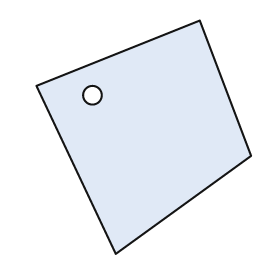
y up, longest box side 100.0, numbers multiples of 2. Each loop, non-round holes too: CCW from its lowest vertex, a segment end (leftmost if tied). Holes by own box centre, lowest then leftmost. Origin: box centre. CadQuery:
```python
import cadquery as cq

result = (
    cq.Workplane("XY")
    .moveTo(-12.0, -50.0)
    .lineTo(46.0, -8.0)
    .lineTo(24.0, 50.0)
    .lineTo(-46.0, 22.0)
    .close()
    .moveTo(-22.0, 18.0)
    .circle(4.0)
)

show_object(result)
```